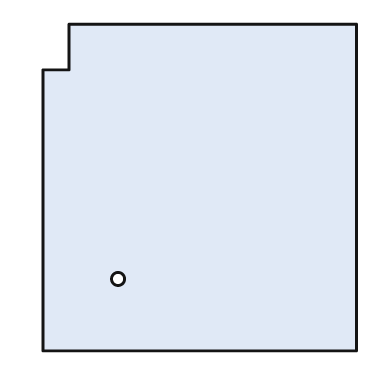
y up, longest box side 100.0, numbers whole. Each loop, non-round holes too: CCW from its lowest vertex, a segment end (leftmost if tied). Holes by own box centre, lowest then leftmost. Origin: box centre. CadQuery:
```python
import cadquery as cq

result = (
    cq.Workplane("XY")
    .moveTo(-48.0, -50.0)
    .lineTo(48.0, -50.0)
    .lineTo(48.0, 50.0)
    .lineTo(-40.0, 50.0)
    .lineTo(-40.0, 36.0)
    .lineTo(-48.0, 36.0)
    .close()
    .moveTo(-25.0, -28.0)
    .circle(2.0)
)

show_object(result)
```